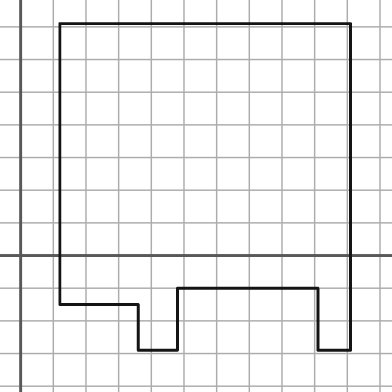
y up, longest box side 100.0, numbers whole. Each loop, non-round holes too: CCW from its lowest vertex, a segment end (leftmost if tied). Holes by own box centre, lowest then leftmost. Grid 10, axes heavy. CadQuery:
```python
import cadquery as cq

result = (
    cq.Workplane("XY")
    .moveTo(36.0, -29.0)
    .lineTo(48.0, -29.0)
    .lineTo(48.0, -10.0)
    .lineTo(91.0, -10.0)
    .lineTo(91.0, -29.0)
    .lineTo(101.0, -29.0)
    .lineTo(101.0, 71.0)
    .lineTo(12.0, 71.0)
    .lineTo(12.0, -15.0)
    .lineTo(36.0, -15.0)
    .close()
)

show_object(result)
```